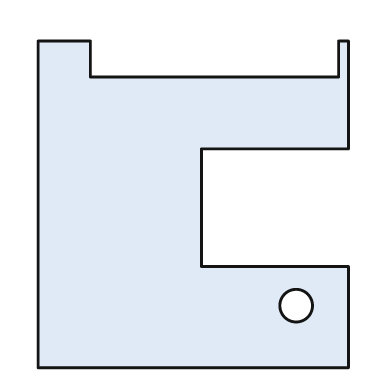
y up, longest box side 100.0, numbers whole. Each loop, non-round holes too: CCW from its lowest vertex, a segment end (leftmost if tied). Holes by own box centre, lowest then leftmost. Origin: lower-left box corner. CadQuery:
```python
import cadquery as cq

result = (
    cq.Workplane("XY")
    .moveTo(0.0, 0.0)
    .lineTo(95.0, 0.0)
    .lineTo(95.0, 31.0)
    .lineTo(50.0, 31.0)
    .lineTo(50.0, 67.0)
    .lineTo(95.0, 67.0)
    .lineTo(95.0, 100.0)
    .lineTo(92.0, 100.0)
    .lineTo(92.0, 89.0)
    .lineTo(16.0, 89.0)
    .lineTo(16.0, 100.0)
    .lineTo(0.0, 100.0)
    .close()
    .moveTo(79.0, 19.0)
    .circle(5.0)
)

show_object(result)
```